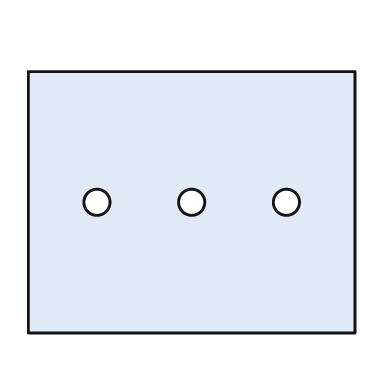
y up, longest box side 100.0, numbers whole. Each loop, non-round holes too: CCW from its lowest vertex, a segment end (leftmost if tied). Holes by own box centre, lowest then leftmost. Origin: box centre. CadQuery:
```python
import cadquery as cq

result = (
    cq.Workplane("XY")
    .moveTo(-50.0, -40.0)
    .lineTo(50.0, -40.0)
    .lineTo(50.0, 40.0)
    .lineTo(-50.0, 40.0)
    .close()
    .moveTo(-29.0, 0.0)
    .circle(4.0)
    .moveTo(0.0, 0.0)
    .circle(4.0)
    .moveTo(29.0, 0.0)
    .circle(4.0)
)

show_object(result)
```